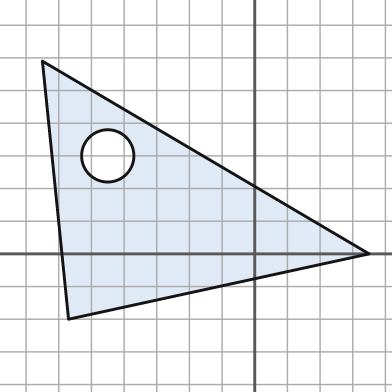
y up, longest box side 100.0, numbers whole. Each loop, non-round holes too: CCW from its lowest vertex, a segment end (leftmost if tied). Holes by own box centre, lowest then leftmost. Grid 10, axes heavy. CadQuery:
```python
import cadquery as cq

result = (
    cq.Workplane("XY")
    .moveTo(-57.0, -20.0)
    .lineTo(35.0, 0.0)
    .lineTo(-65.0, 59.0)
    .close()
    .moveTo(-45.0, 30.0)
    .circle(8.0)
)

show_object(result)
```